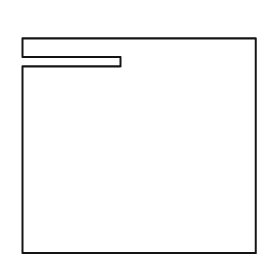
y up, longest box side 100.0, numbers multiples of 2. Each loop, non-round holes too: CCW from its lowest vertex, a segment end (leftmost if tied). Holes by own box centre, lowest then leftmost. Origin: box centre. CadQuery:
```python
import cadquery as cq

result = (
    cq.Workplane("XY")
    .moveTo(-50.0, -46.0)
    .lineTo(50.0, -46.0)
    .lineTo(50.0, 46.0)
    .lineTo(-50.0, 46.0)
    .lineTo(-50.0, 38.0)
    .lineTo(-8.0, 38.0)
    .lineTo(-8.0, 34.0)
    .lineTo(-50.0, 34.0)
    .close()
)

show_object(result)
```